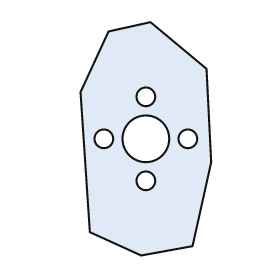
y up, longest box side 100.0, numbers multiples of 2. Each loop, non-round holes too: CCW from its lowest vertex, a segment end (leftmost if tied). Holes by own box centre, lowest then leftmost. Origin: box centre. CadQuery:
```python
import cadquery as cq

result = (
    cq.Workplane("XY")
    .moveTo(-2.0, -50.0)
    .lineTo(20.0, -46.0)
    .lineTo(28.0, -10.0)
    .lineTo(26.0, 30.0)
    .lineTo(2.0, 50.0)
    .lineTo(-16.0, 46.0)
    .lineTo(-28.0, 20.0)
    .lineTo(-24.0, -40.0)
    .close()
    .moveTo(0.0, -18.0)
    .circle(4.0)
    .moveTo(-18.0, 0.0)
    .circle(4.0)
    .moveTo(0.0, 0.0)
    .circle(10.0)
    .moveTo(18.0, 0.0)
    .circle(4.0)
    .moveTo(0.0, 18.0)
    .circle(4.0)
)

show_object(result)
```